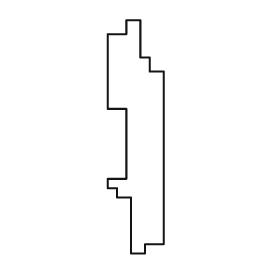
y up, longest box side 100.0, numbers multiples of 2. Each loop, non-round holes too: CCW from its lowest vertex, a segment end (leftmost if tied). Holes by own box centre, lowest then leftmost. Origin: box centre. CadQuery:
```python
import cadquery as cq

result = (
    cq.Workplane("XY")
    .moveTo(-2.0, -50.0)
    .lineTo(4.0, -50.0)
    .lineTo(4.0, -46.0)
    .lineTo(12.0, -46.0)
    .lineTo(12.0, 28.0)
    .lineTo(6.0, 28.0)
    .lineTo(6.0, 34.0)
    .lineTo(2.0, 34.0)
    .lineTo(2.0, 50.0)
    .lineTo(-4.0, 50.0)
    .lineTo(-4.0, 44.0)
    .lineTo(-12.0, 44.0)
    .lineTo(-12.0, 12.0)
    .lineTo(-4.0, 12.0)
    .lineTo(-4.0, -18.0)
    .lineTo(-12.0, -18.0)
    .lineTo(-12.0, -22.0)
    .lineTo(-8.0, -22.0)
    .lineTo(-8.0, -26.0)
    .lineTo(-2.0, -26.0)
    .close()
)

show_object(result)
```